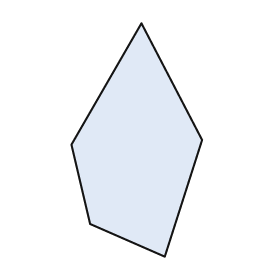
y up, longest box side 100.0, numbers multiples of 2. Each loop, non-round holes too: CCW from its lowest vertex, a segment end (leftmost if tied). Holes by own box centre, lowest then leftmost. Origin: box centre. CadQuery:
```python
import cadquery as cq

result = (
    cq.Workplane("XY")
    .moveTo(12.0, -50.0)
    .lineTo(28.0, 0.0)
    .lineTo(2.0, 50.0)
    .lineTo(-28.0, -2.0)
    .lineTo(-20.0, -36.0)
    .close()
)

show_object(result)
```